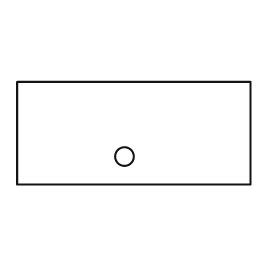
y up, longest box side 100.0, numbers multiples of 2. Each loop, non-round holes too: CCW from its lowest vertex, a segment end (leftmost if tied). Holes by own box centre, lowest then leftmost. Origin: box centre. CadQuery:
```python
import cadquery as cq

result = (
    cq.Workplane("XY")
    .moveTo(-50.0, -22.0)
    .lineTo(50.0, -22.0)
    .lineTo(50.0, 22.0)
    .lineTo(-50.0, 22.0)
    .close()
    .moveTo(-4.0, -10.0)
    .circle(4.0)
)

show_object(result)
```